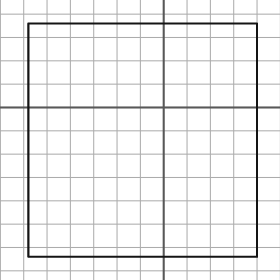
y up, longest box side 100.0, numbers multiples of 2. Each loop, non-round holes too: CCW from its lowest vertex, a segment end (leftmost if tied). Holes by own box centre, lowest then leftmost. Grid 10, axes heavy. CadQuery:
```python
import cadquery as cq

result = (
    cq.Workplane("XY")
    .moveTo(-58.0, -64.0)
    .lineTo(40.0, -64.0)
    .lineTo(40.0, 36.0)
    .lineTo(-58.0, 36.0)
    .close()
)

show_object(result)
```